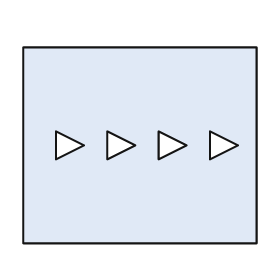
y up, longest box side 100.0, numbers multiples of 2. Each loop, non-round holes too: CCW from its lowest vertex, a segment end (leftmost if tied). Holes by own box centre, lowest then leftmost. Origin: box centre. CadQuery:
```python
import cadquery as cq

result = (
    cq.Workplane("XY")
    .moveTo(-50.0, -42.0)
    .lineTo(50.0, -42.0)
    .lineTo(50.0, 42.0)
    .lineTo(-50.0, 42.0)
    .close()
    .moveTo(-36.0, -6.0)
    .lineTo(-24.0, 0.0)
    .lineTo(-36.0, 6.0)
    .close()
    .moveTo(-14.0, -6.0)
    .lineTo(-2.0, 0.0)
    .lineTo(-14.0, 6.0)
    .close()
    .moveTo(8.0, -6.0)
    .lineTo(20.0, 0.0)
    .lineTo(8.0, 6.0)
    .close()
    .moveTo(30.0, -6.0)
    .lineTo(42.0, 0.0)
    .lineTo(30.0, 6.0)
    .close()
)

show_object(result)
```